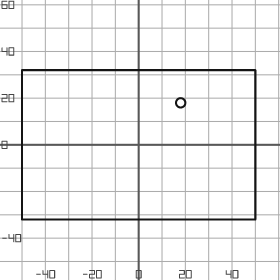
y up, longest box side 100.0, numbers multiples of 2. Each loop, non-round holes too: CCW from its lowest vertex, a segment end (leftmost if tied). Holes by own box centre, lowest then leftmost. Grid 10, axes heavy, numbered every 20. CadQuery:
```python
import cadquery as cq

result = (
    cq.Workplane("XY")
    .moveTo(-50.0, -32.0)
    .lineTo(50.0, -32.0)
    .lineTo(50.0, 32.0)
    .lineTo(-50.0, 32.0)
    .close()
    .moveTo(18.0, 18.0)
    .circle(2.0)
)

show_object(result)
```